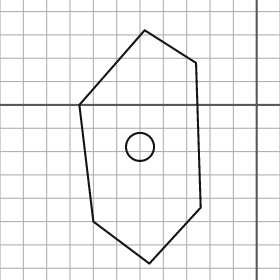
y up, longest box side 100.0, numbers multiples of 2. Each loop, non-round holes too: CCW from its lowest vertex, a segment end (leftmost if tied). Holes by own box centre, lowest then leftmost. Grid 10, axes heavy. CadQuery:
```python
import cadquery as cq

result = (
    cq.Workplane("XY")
    .moveTo(-46.0, -68.0)
    .lineTo(-24.0, -44.0)
    .lineTo(-26.0, 18.0)
    .lineTo(-48.0, 32.0)
    .lineTo(-76.0, 0.0)
    .lineTo(-70.0, -50.0)
    .close()
    .moveTo(-50.0, -18.0)
    .circle(6.0)
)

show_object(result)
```